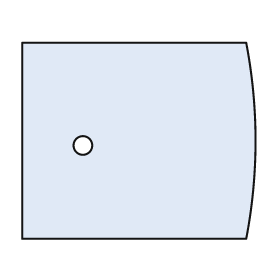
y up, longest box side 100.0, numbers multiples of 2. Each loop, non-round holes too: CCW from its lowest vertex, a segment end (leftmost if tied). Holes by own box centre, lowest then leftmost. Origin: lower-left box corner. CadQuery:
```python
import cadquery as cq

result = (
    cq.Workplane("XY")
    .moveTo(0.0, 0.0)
    .lineTo(96.0, 0.0)
    .threePointArc((100.0, 42.0), (96.0, 84.0))
    .lineTo(0.0, 84.0)
    .close()
    .moveTo(26.0, 40.0)
    .circle(4.0)
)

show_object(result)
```